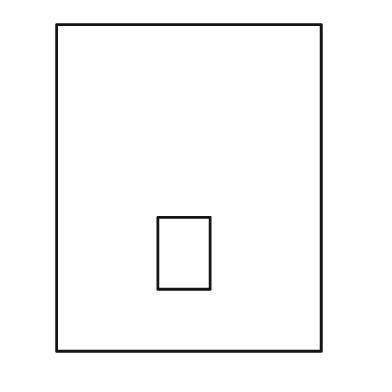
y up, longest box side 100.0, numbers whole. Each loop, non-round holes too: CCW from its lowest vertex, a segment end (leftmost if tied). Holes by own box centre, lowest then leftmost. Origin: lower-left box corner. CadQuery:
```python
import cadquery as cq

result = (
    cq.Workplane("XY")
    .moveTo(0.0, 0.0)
    .lineTo(81.0, 0.0)
    .lineTo(81.0, 100.0)
    .lineTo(0.0, 100.0)
    .close()
    .moveTo(31.0, 19.0)
    .lineTo(47.0, 19.0)
    .lineTo(47.0, 41.0)
    .lineTo(31.0, 41.0)
    .close()
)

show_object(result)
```